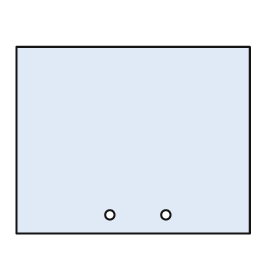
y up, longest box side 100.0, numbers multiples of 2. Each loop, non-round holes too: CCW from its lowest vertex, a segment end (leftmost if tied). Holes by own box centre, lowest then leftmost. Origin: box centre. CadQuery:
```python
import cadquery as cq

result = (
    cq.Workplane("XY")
    .moveTo(-50.0, -40.0)
    .lineTo(50.0, -40.0)
    .lineTo(50.0, 40.0)
    .lineTo(-50.0, 40.0)
    .close()
    .moveTo(-10.0, -32.0)
    .circle(2.0)
    .moveTo(14.0, -32.0)
    .circle(2.0)
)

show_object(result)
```